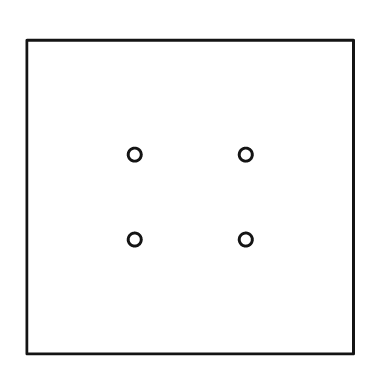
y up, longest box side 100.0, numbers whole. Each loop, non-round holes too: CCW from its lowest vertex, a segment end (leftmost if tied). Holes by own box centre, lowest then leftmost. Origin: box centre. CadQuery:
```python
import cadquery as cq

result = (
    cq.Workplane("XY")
    .moveTo(-50.0, -48.0)
    .lineTo(50.0, -48.0)
    .lineTo(50.0, 48.0)
    .lineTo(-50.0, 48.0)
    .close()
    .moveTo(-17.0, -13.0)
    .circle(2.0)
    .moveTo(17.0, -13.0)
    .circle(2.0)
    .moveTo(-17.0, 13.0)
    .circle(2.0)
    .moveTo(17.0, 13.0)
    .circle(2.0)
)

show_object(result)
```